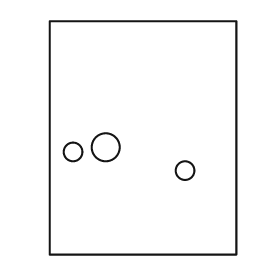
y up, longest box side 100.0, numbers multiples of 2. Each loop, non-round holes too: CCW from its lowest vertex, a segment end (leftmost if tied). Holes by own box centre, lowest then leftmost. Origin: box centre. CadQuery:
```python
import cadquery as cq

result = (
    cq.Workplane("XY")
    .moveTo(-40.0, -50.0)
    .lineTo(40.0, -50.0)
    .lineTo(40.0, 50.0)
    .lineTo(-40.0, 50.0)
    .close()
    .moveTo(18.0, -14.0)
    .circle(4.0)
    .moveTo(-30.0, -6.0)
    .circle(4.0)
    .moveTo(-16.0, -4.0)
    .circle(6.0)
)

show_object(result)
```